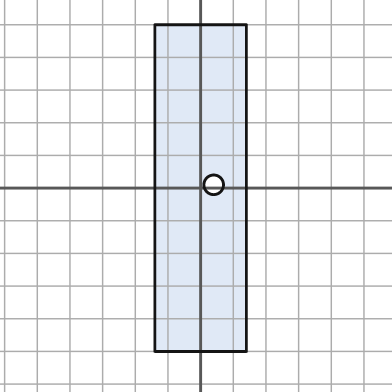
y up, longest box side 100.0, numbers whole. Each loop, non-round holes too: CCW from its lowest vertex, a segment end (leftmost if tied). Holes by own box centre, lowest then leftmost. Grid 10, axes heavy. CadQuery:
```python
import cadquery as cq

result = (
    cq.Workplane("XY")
    .moveTo(-14.0, -50.0)
    .lineTo(14.0, -50.0)
    .lineTo(14.0, 50.0)
    .lineTo(-14.0, 50.0)
    .close()
    .moveTo(4.0, 1.0)
    .circle(3.0)
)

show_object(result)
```